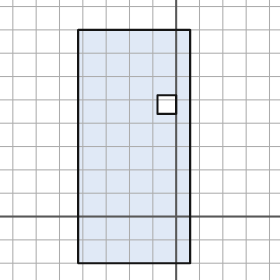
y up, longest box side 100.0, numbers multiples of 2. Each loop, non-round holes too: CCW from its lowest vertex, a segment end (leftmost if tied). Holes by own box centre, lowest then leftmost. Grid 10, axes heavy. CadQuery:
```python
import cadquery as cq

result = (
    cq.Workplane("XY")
    .moveTo(-42.0, -20.0)
    .lineTo(6.0, -20.0)
    .lineTo(6.0, 80.0)
    .lineTo(-42.0, 80.0)
    .close()
    .moveTo(-8.0, 44.0)
    .lineTo(0.0, 44.0)
    .lineTo(0.0, 52.0)
    .lineTo(-8.0, 52.0)
    .close()
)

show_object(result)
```